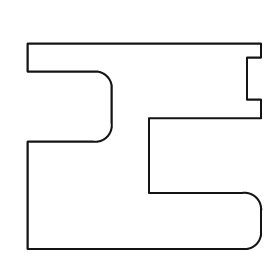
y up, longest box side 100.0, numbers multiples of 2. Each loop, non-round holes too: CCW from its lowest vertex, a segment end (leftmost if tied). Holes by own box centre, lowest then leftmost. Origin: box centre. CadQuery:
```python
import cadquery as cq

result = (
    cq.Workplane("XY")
    .moveTo(-50.0, -44.0)
    .lineTo(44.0, -44.0)
    .threePointArc((48.0, -42.0), (50.0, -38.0))
    .lineTo(50.0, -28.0)
    .threePointArc((48.0, -22.0), (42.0, -20.0))
    .lineTo(2.0, -20.0)
    .lineTo(2.0, 12.0)
    .lineTo(50.0, 12.0)
    .lineTo(50.0, 20.0)
    .lineTo(44.0, 20.0)
    .lineTo(44.0, 38.0)
    .lineTo(50.0, 38.0)
    .lineTo(50.0, 44.0)
    .lineTo(-50.0, 44.0)
    .lineTo(-50.0, 32.0)
    .lineTo(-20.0, 32.0)
    .threePointArc((-16.0, 30.0), (-14.0, 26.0))
    .lineTo(-14.0, 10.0)
    .threePointArc((-16.0, 4.0), (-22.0, 2.0))
    .lineTo(-50.0, 2.0)
    .close()
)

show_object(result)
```